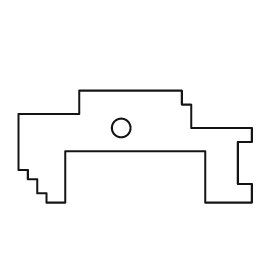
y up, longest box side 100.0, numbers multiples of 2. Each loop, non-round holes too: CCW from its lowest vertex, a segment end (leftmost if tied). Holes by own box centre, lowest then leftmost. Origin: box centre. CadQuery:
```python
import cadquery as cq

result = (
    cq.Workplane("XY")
    .moveTo(-38.0, -24.0)
    .lineTo(-30.0, -24.0)
    .lineTo(-30.0, -2.0)
    .lineTo(30.0, -2.0)
    .lineTo(30.0, -24.0)
    .lineTo(50.0, -24.0)
    .lineTo(50.0, -16.0)
    .lineTo(44.0, -16.0)
    .lineTo(44.0, 2.0)
    .lineTo(50.0, 2.0)
    .lineTo(50.0, 8.0)
    .lineTo(24.0, 8.0)
    .lineTo(24.0, 18.0)
    .lineTo(20.0, 18.0)
    .lineTo(20.0, 24.0)
    .lineTo(-24.0, 24.0)
    .lineTo(-24.0, 14.0)
    .lineTo(-50.0, 14.0)
    .lineTo(-50.0, -10.0)
    .lineTo(-46.0, -10.0)
    .lineTo(-46.0, -14.0)
    .lineTo(-42.0, -14.0)
    .lineTo(-42.0, -20.0)
    .lineTo(-38.0, -20.0)
    .close()
    .moveTo(-6.0, 8.0)
    .circle(4.0)
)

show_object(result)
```